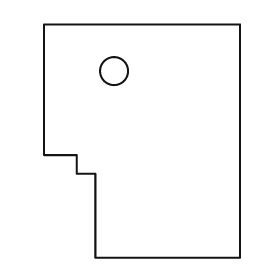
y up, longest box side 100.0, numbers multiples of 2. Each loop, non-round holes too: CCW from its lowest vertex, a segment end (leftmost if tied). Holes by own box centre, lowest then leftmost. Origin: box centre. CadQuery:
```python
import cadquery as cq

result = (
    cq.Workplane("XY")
    .moveTo(-20.0, -50.0)
    .lineTo(42.0, -50.0)
    .lineTo(42.0, 50.0)
    .lineTo(-42.0, 50.0)
    .lineTo(-42.0, -6.0)
    .lineTo(-28.0, -6.0)
    .lineTo(-28.0, -14.0)
    .lineTo(-20.0, -14.0)
    .close()
    .moveTo(-12.0, 30.0)
    .circle(6.0)
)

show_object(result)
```